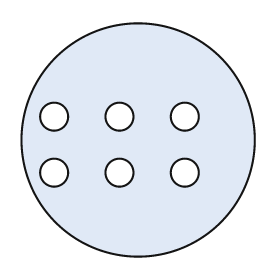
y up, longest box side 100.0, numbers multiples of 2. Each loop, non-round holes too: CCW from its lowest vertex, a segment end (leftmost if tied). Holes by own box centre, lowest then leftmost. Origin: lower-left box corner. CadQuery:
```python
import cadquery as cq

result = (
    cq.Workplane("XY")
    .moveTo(50.0, 50.0)
    .circle(50.0)
    .moveTo(14.0, 36.0)
    .circle(6.0)
    .moveTo(42.0, 36.0)
    .circle(6.0)
    .moveTo(70.0, 36.0)
    .circle(6.0)
    .moveTo(14.0, 60.0)
    .circle(6.0)
    .moveTo(42.0, 60.0)
    .circle(6.0)
    .moveTo(70.0, 60.0)
    .circle(6.0)
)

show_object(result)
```